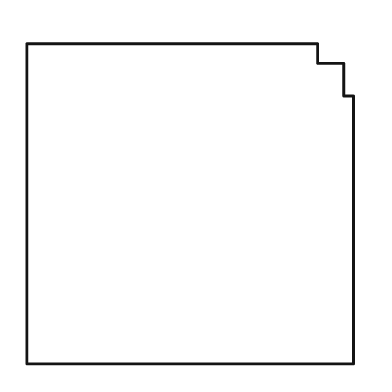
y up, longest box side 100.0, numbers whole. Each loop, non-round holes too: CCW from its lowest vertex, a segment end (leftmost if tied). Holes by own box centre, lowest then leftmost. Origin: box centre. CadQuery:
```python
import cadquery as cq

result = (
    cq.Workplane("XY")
    .moveTo(-50.0, -49.0)
    .lineTo(50.0, -49.0)
    .lineTo(50.0, 33.0)
    .lineTo(47.0, 33.0)
    .lineTo(47.0, 43.0)
    .lineTo(39.0, 43.0)
    .lineTo(39.0, 49.0)
    .lineTo(-50.0, 49.0)
    .close()
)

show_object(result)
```